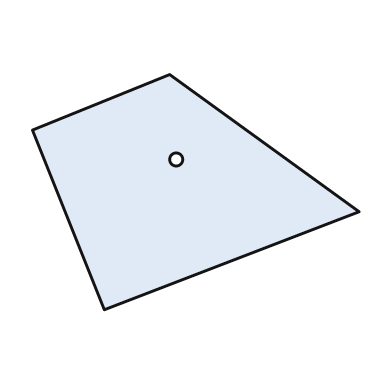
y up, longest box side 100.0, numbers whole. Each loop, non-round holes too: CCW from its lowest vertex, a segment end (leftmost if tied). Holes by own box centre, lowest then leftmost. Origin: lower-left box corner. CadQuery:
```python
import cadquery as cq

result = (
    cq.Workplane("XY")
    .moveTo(22.0, 0.0)
    .lineTo(100.0, 30.0)
    .lineTo(42.0, 72.0)
    .lineTo(0.0, 55.0)
    .close()
    .moveTo(44.0, 46.0)
    .circle(2.0)
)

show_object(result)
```